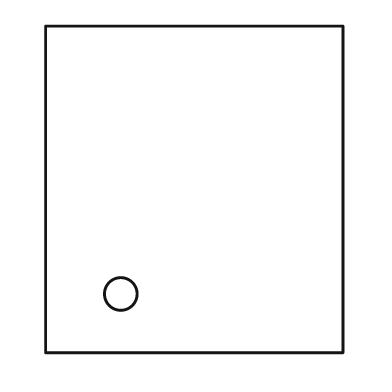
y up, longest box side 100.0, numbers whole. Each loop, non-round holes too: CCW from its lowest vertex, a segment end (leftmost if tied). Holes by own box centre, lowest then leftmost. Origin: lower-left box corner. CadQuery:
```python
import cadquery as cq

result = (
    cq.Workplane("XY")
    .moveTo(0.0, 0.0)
    .lineTo(91.0, 0.0)
    .lineTo(91.0, 100.0)
    .lineTo(0.0, 100.0)
    .close()
    .moveTo(23.0, 18.0)
    .circle(5.0)
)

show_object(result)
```